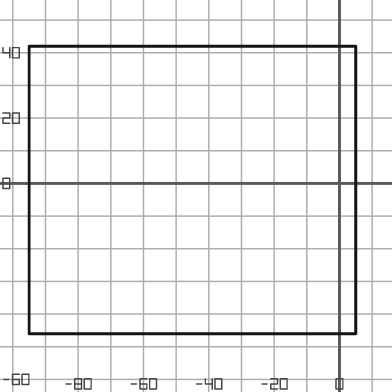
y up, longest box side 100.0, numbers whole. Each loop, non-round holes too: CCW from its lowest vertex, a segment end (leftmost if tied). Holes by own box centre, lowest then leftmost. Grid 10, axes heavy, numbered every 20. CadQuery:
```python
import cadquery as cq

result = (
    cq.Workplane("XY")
    .moveTo(-95.0, -46.0)
    .lineTo(5.0, -46.0)
    .lineTo(5.0, 42.0)
    .lineTo(-95.0, 42.0)
    .close()
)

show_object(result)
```